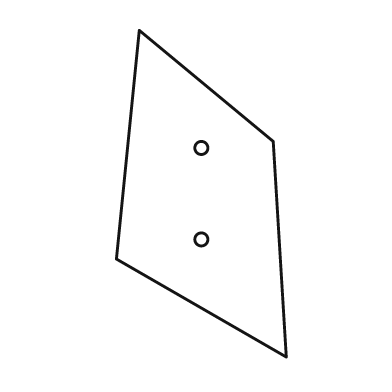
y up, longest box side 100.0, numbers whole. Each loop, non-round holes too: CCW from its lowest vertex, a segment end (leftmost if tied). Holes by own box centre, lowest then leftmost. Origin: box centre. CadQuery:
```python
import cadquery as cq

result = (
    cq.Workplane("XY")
    .moveTo(26.0, -50.0)
    .lineTo(22.0, 16.0)
    .lineTo(-19.0, 50.0)
    .lineTo(-26.0, -20.0)
    .close()
    .moveTo(0.0, -14.0)
    .circle(2.0)
    .moveTo(0.0, 14.0)
    .circle(2.0)
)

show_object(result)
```